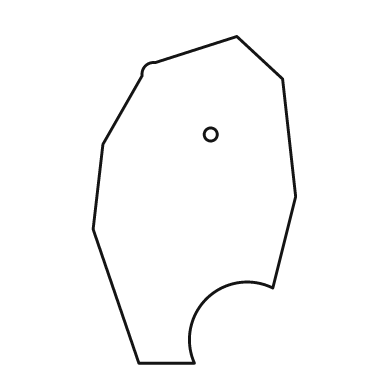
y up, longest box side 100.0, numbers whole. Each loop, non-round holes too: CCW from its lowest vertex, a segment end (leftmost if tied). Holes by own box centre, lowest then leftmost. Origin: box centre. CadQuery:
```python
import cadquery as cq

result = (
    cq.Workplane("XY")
    .moveTo(-17.0, -50.0)
    .lineTo(0.0, -50.0)
    .threePointArc((4.0, -30.0), (24.0, -27.0))
    .lineTo(31.0, 1.0)
    .lineTo(27.0, 37.0)
    .lineTo(13.0, 50.0)
    .lineTo(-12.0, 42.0)
    .threePointArc((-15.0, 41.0), (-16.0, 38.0))
    .lineTo(-28.0, 17.0)
    .lineTo(-31.0, -9.0)
    .close()
    .moveTo(5.0, 20.0)
    .circle(2.0)
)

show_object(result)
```